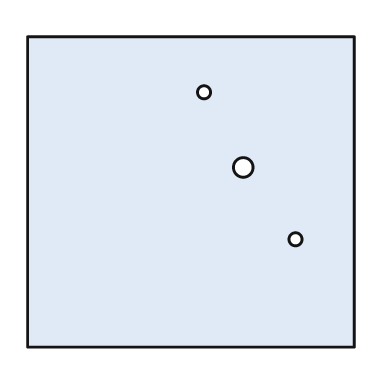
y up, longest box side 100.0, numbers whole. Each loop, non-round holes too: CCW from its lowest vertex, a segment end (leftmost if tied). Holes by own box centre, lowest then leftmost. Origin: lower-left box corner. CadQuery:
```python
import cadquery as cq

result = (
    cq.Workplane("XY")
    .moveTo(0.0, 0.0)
    .lineTo(100.0, 0.0)
    .lineTo(100.0, 95.0)
    .lineTo(0.0, 95.0)
    .close()
    .moveTo(82.0, 33.0)
    .circle(2.0)
    .moveTo(66.0, 55.0)
    .circle(3.0)
    .moveTo(54.0, 78.0)
    .circle(2.0)
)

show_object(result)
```